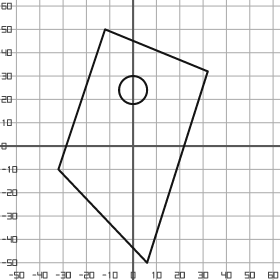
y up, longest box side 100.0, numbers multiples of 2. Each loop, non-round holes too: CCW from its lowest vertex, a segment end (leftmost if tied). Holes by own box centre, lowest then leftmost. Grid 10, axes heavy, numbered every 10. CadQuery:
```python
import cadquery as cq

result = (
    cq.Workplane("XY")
    .moveTo(6.0, -50.0)
    .lineTo(32.0, 32.0)
    .lineTo(-12.0, 50.0)
    .lineTo(-32.0, -10.0)
    .close()
    .moveTo(0.0, 24.0)
    .circle(6.0)
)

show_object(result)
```